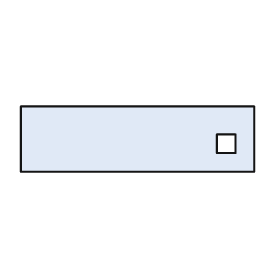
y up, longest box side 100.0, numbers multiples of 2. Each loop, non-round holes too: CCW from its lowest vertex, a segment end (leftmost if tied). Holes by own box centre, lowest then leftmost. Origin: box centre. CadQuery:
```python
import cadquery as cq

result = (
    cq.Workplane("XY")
    .moveTo(-50.0, -14.0)
    .lineTo(50.0, -14.0)
    .lineTo(50.0, 14.0)
    .lineTo(-50.0, 14.0)
    .close()
    .moveTo(34.0, -6.0)
    .lineTo(42.0, -6.0)
    .lineTo(42.0, 2.0)
    .lineTo(34.0, 2.0)
    .close()
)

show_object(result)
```